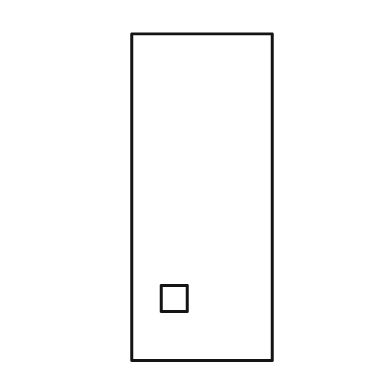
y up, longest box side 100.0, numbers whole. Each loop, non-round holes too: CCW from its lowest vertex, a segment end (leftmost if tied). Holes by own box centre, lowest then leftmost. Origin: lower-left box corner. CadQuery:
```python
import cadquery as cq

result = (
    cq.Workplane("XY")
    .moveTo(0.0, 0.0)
    .lineTo(43.0, 0.0)
    .lineTo(43.0, 100.0)
    .lineTo(0.0, 100.0)
    .close()
    .moveTo(9.0, 15.0)
    .lineTo(17.0, 15.0)
    .lineTo(17.0, 23.0)
    .lineTo(9.0, 23.0)
    .close()
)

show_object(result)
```